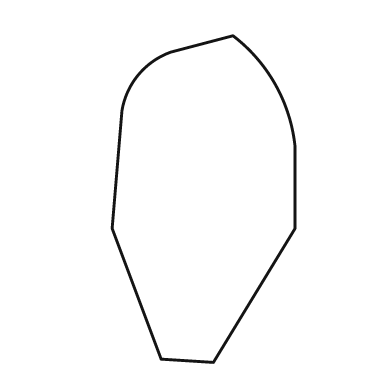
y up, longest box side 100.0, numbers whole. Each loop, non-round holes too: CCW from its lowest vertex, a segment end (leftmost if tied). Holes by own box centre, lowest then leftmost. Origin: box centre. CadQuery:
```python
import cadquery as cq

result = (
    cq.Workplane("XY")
    .moveTo(3.0, -50.0)
    .lineTo(28.0, -9.0)
    .lineTo(28.0, 16.0)
    .threePointArc((22.0, 35.0), (9.0, 50.0))
    .lineTo(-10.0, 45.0)
    .threePointArc((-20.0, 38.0), (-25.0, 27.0))
    .lineTo(-28.0, -9.0)
    .lineTo(-13.0, -49.0)
    .close()
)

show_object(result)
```